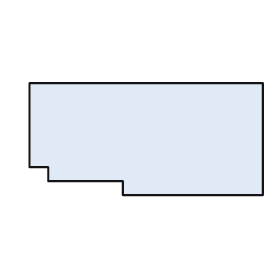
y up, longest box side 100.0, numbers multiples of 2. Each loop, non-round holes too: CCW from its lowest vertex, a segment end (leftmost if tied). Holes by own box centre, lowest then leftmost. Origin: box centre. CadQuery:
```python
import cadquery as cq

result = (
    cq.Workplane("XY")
    .moveTo(-10.0, -24.0)
    .lineTo(50.0, -24.0)
    .lineTo(50.0, 24.0)
    .lineTo(-50.0, 24.0)
    .lineTo(-50.0, -12.0)
    .lineTo(-42.0, -12.0)
    .lineTo(-42.0, -18.0)
    .lineTo(-10.0, -18.0)
    .close()
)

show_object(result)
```